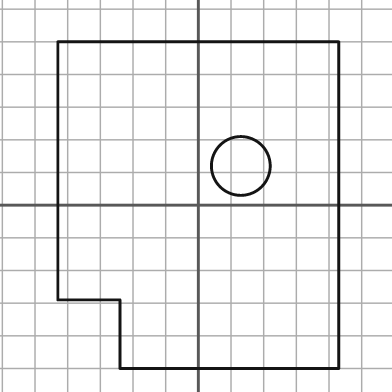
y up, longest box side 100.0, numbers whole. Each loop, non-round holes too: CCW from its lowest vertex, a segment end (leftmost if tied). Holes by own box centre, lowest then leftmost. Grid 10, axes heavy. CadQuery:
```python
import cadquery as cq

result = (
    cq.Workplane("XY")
    .moveTo(-24.0, -50.0)
    .lineTo(43.0, -50.0)
    .lineTo(43.0, 50.0)
    .lineTo(-43.0, 50.0)
    .lineTo(-43.0, -29.0)
    .lineTo(-24.0, -29.0)
    .close()
    .moveTo(13.0, 12.0)
    .circle(9.0)
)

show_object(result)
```